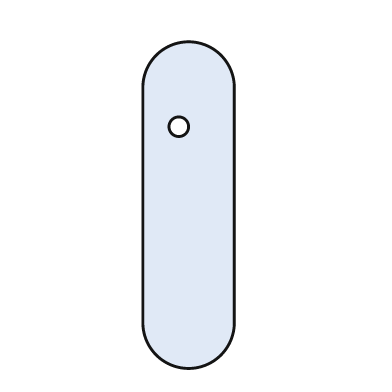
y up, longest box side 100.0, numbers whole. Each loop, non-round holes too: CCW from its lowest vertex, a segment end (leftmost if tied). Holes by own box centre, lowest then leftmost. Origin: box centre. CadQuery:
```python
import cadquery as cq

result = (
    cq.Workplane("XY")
    .moveTo(-14.0, -36.0)
    .threePointArc((0.0, -50.0), (14.0, -36.0))
    .lineTo(14.0, 36.0)
    .threePointArc((0.0, 50.0), (-14.0, 36.0))
    .close()
    .moveTo(-3.0, 24.0)
    .circle(3.0)
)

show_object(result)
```